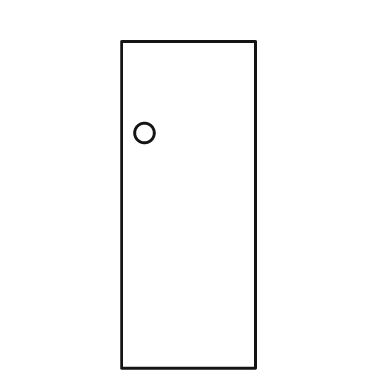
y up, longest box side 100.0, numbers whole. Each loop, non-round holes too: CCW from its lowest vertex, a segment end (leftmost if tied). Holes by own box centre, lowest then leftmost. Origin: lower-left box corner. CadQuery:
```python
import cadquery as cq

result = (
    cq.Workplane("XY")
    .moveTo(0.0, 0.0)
    .lineTo(41.0, 0.0)
    .lineTo(41.0, 100.0)
    .lineTo(0.0, 100.0)
    .close()
    .moveTo(7.0, 72.0)
    .circle(3.0)
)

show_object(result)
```